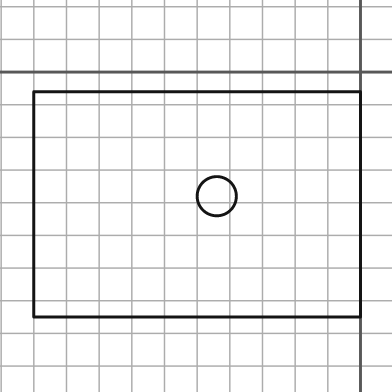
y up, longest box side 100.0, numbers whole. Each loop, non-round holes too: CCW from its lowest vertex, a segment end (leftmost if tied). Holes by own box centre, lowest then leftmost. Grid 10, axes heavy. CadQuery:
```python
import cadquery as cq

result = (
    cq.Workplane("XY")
    .moveTo(-100.0, -75.0)
    .lineTo(0.0, -75.0)
    .lineTo(0.0, -6.0)
    .lineTo(-100.0, -6.0)
    .close()
    .moveTo(-44.0, -38.0)
    .circle(6.0)
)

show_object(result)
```